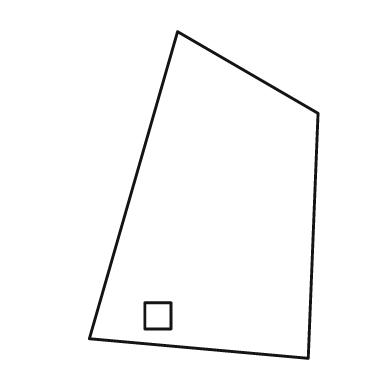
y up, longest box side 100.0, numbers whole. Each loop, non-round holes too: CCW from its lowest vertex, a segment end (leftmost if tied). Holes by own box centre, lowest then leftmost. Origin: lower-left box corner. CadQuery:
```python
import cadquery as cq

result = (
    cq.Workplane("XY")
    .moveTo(67.0, 0.0)
    .lineTo(70.0, 75.0)
    .lineTo(27.0, 100.0)
    .lineTo(0.0, 6.0)
    .close()
    .moveTo(17.0, 9.0)
    .lineTo(25.0, 9.0)
    .lineTo(25.0, 17.0)
    .lineTo(17.0, 17.0)
    .close()
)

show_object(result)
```